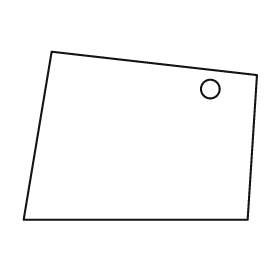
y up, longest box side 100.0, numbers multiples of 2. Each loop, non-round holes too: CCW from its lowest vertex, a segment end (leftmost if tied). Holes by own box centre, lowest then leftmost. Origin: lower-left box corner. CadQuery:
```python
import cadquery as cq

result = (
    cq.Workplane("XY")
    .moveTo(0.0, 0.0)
    .lineTo(96.0, 0.0)
    .lineTo(100.0, 62.0)
    .lineTo(12.0, 72.0)
    .close()
    .moveTo(80.0, 56.0)
    .circle(4.0)
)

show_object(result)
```